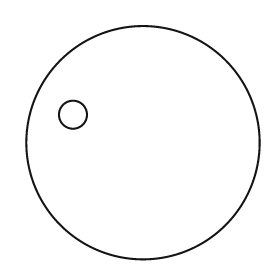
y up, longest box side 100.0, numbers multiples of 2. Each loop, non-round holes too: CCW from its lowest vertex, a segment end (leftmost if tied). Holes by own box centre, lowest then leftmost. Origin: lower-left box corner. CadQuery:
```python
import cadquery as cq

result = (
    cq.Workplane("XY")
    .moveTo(50.0, 50.0)
    .circle(50.0)
    .moveTo(20.0, 62.0)
    .circle(6.0)
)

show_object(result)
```